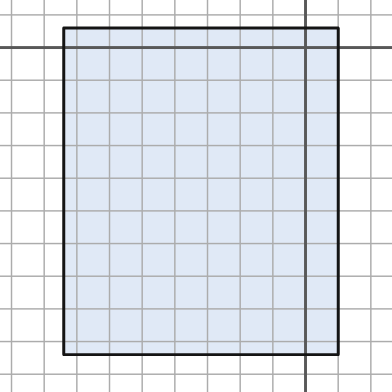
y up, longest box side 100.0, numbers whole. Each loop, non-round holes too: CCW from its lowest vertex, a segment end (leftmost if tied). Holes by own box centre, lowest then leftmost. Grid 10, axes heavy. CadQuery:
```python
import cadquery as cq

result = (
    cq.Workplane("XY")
    .moveTo(-74.0, -94.0)
    .lineTo(10.0, -94.0)
    .lineTo(10.0, 6.0)
    .lineTo(-74.0, 6.0)
    .close()
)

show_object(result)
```